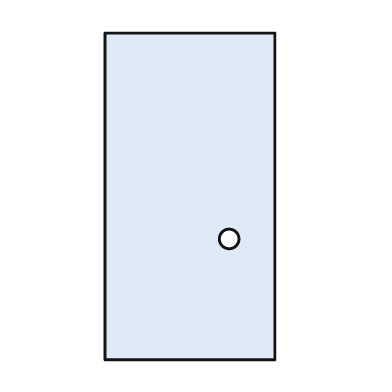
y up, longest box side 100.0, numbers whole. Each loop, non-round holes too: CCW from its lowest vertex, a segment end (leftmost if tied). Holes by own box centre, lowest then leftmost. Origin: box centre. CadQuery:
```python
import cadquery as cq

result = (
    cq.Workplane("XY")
    .moveTo(-26.0, -50.0)
    .lineTo(26.0, -50.0)
    .lineTo(26.0, 50.0)
    .lineTo(-26.0, 50.0)
    .close()
    .moveTo(12.0, -13.0)
    .circle(3.0)
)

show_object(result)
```